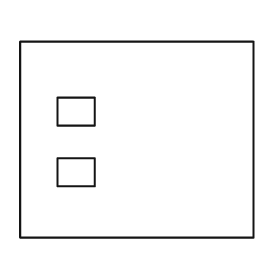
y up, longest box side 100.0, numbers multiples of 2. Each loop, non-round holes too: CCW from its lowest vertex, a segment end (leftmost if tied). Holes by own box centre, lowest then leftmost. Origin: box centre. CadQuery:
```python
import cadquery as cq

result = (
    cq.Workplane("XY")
    .moveTo(-50.0, -42.0)
    .lineTo(50.0, -42.0)
    .lineTo(50.0, 42.0)
    .lineTo(-50.0, 42.0)
    .close()
    .moveTo(-34.0, -20.0)
    .lineTo(-18.0, -20.0)
    .lineTo(-18.0, -8.0)
    .lineTo(-34.0, -8.0)
    .close()
    .moveTo(-34.0, 6.0)
    .lineTo(-18.0, 6.0)
    .lineTo(-18.0, 18.0)
    .lineTo(-34.0, 18.0)
    .close()
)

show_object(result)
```